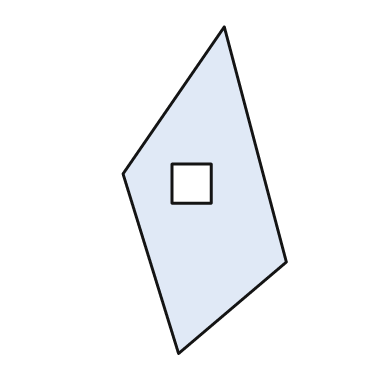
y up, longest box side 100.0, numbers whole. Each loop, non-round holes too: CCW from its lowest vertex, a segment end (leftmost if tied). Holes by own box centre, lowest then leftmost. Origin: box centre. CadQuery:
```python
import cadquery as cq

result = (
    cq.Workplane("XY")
    .moveTo(-8.0, -50.0)
    .lineTo(25.0, -22.0)
    .lineTo(6.0, 50.0)
    .lineTo(-25.0, 5.0)
    .close()
    .moveTo(-10.0, -4.0)
    .lineTo(2.0, -4.0)
    .lineTo(2.0, 8.0)
    .lineTo(-10.0, 8.0)
    .close()
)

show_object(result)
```